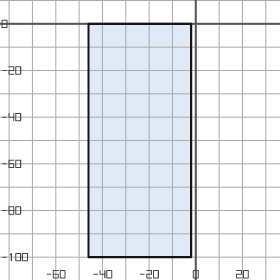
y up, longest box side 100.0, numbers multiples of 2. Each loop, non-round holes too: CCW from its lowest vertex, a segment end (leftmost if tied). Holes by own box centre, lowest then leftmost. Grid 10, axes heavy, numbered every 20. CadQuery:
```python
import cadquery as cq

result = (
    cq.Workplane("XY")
    .moveTo(-46.0, -100.0)
    .lineTo(-2.0, -100.0)
    .lineTo(-2.0, 0.0)
    .lineTo(-46.0, 0.0)
    .close()
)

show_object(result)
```